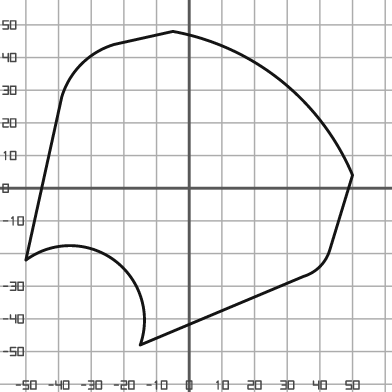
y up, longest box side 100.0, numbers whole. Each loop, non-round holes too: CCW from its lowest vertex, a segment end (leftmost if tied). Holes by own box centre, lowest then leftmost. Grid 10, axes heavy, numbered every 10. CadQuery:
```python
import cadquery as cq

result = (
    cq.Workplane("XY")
    .moveTo(-15.0, -48.0)
    .lineTo(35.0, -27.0)
    .threePointArc((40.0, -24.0), (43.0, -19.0))
    .lineTo(50.0, 4.0)
    .threePointArc((28.0, 33.0), (-5.0, 48.0))
    .lineTo(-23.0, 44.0)
    .threePointArc((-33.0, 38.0), (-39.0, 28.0))
    .lineTo(-50.0, -22.0)
    .threePointArc((-23.0, -22.0), (-15.0, -48.0))
    .close()
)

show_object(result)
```